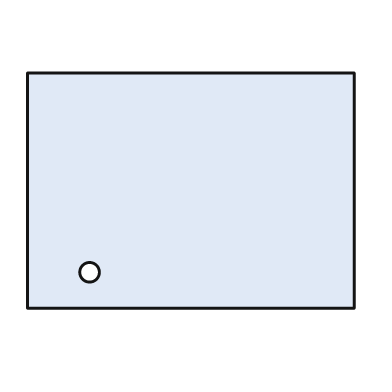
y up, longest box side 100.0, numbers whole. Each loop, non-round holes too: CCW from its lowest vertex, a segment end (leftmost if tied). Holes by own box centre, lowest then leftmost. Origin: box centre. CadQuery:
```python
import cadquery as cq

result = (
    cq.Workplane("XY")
    .moveTo(-50.0, -36.0)
    .lineTo(50.0, -36.0)
    .lineTo(50.0, 36.0)
    .lineTo(-50.0, 36.0)
    .close()
    .moveTo(-31.0, -25.0)
    .circle(3.0)
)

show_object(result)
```